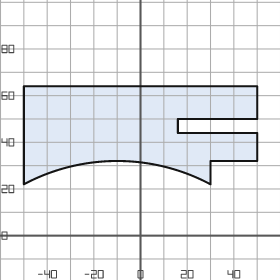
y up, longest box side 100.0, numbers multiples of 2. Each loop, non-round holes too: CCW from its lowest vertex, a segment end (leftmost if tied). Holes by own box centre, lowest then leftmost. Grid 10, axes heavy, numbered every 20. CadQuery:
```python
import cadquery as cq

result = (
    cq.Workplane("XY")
    .moveTo(-50.0, 22.0)
    .threePointArc((-10.0, 32.0), (30.0, 22.0))
    .lineTo(30.0, 32.0)
    .lineTo(50.0, 32.0)
    .lineTo(50.0, 44.0)
    .lineTo(16.0, 44.0)
    .lineTo(16.0, 50.0)
    .lineTo(50.0, 50.0)
    .lineTo(50.0, 64.0)
    .lineTo(-50.0, 64.0)
    .close()
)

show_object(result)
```